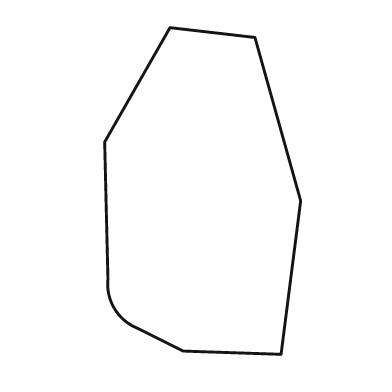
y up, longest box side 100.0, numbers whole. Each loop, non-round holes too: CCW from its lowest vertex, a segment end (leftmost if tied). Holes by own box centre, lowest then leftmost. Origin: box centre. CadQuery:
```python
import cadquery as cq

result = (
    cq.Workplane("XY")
    .moveTo(24.0, -50.0)
    .lineTo(30.0, -3.0)
    .lineTo(16.0, 47.0)
    .lineTo(-10.0, 50.0)
    .lineTo(-30.0, 15.0)
    .lineTo(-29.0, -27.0)
    .threePointArc((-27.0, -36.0), (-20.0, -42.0))
    .lineTo(-6.0, -49.0)
    .close()
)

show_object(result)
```